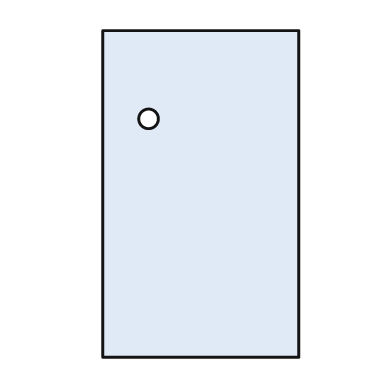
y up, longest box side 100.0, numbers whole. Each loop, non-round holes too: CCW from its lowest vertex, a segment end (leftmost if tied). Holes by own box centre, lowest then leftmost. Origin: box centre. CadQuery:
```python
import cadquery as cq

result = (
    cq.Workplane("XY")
    .moveTo(-30.0, -50.0)
    .lineTo(30.0, -50.0)
    .lineTo(30.0, 50.0)
    .lineTo(-30.0, 50.0)
    .close()
    .moveTo(-16.0, 23.0)
    .circle(3.0)
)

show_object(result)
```